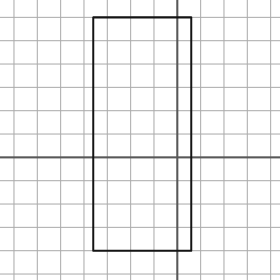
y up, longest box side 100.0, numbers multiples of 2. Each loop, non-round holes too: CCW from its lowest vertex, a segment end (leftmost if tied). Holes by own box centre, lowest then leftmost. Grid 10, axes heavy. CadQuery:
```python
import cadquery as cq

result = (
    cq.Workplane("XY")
    .moveTo(-36.0, -40.0)
    .lineTo(6.0, -40.0)
    .lineTo(6.0, 60.0)
    .lineTo(-36.0, 60.0)
    .close()
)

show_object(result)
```